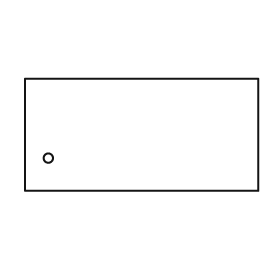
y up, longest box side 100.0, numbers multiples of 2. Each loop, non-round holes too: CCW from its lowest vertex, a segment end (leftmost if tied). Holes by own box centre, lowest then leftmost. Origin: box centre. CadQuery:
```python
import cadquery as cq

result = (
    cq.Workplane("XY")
    .moveTo(-50.0, -24.0)
    .lineTo(50.0, -24.0)
    .lineTo(50.0, 24.0)
    .lineTo(-50.0, 24.0)
    .close()
    .moveTo(-40.0, -10.0)
    .circle(2.0)
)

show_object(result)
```